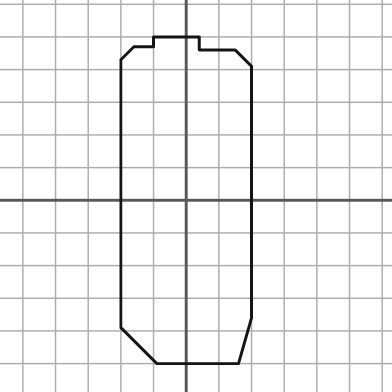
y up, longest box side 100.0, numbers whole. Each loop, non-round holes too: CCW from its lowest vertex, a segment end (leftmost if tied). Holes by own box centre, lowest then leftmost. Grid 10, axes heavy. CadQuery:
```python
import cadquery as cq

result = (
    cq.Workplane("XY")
    .moveTo(-9.0, -50.0)
    .lineTo(16.0, -50.0)
    .lineTo(20.0, -36.0)
    .lineTo(20.0, 41.0)
    .lineTo(15.0, 46.0)
    .lineTo(4.0, 46.0)
    .lineTo(4.0, 50.0)
    .lineTo(-10.0, 50.0)
    .lineTo(-10.0, 47.0)
    .lineTo(-16.0, 47.0)
    .lineTo(-20.0, 43.0)
    .lineTo(-20.0, -39.0)
    .close()
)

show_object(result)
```